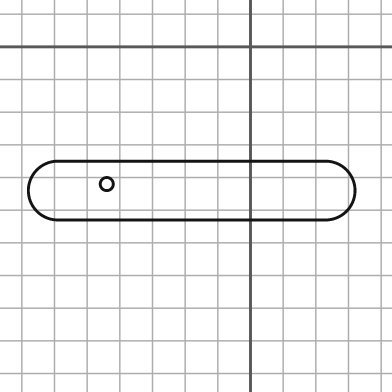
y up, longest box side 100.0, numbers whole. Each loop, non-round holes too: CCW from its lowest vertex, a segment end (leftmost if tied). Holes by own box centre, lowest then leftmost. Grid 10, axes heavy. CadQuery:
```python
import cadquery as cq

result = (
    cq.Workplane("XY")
    .moveTo(-59.0, -53.0)
    .lineTo(23.0, -53.0)
    .threePointArc((32.0, -44.0), (23.0, -35.0))
    .lineTo(-59.0, -35.0)
    .threePointArc((-68.0, -44.0), (-59.0, -53.0))
    .close()
    .moveTo(-44.0, -42.0)
    .circle(2.0)
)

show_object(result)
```